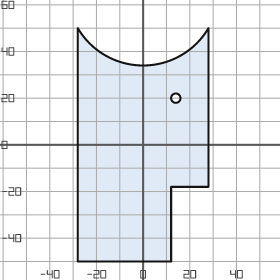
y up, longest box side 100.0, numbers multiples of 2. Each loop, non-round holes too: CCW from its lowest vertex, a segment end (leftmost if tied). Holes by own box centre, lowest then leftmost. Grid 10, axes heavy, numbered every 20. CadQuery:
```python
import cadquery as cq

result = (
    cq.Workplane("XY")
    .moveTo(-28.0, -50.0)
    .lineTo(12.0, -50.0)
    .lineTo(12.0, -18.0)
    .lineTo(28.0, -18.0)
    .lineTo(28.0, 50.0)
    .threePointArc((0.0, 34.0), (-28.0, 50.0))
    .close()
    .moveTo(14.0, 20.0)
    .circle(2.0)
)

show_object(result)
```